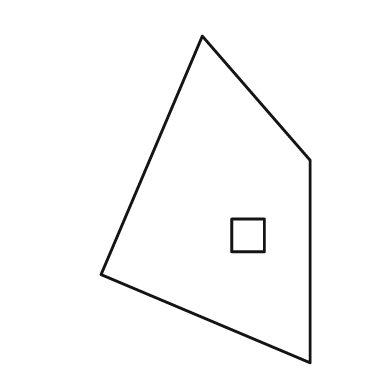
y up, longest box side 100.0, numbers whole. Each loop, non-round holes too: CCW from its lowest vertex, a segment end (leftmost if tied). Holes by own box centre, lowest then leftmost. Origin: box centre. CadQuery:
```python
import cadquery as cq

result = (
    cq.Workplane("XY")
    .moveTo(32.0, -50.0)
    .lineTo(32.0, 12.0)
    .lineTo(-1.0, 50.0)
    .lineTo(-32.0, -23.0)
    .close()
    .moveTo(8.0, -16.0)
    .lineTo(18.0, -16.0)
    .lineTo(18.0, -6.0)
    .lineTo(8.0, -6.0)
    .close()
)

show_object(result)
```